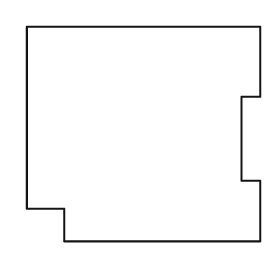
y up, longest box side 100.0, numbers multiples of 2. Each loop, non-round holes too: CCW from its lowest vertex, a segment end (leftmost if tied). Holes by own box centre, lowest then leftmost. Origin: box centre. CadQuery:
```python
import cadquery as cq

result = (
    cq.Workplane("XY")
    .moveTo(-34.0, -46.0)
    .lineTo(50.0, -46.0)
    .lineTo(50.0, -20.0)
    .lineTo(42.0, -20.0)
    .lineTo(42.0, 16.0)
    .lineTo(50.0, 16.0)
    .lineTo(50.0, 46.0)
    .lineTo(-50.0, 46.0)
    .lineTo(-50.0, -32.0)
    .lineTo(-34.0, -32.0)
    .close()
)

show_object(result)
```